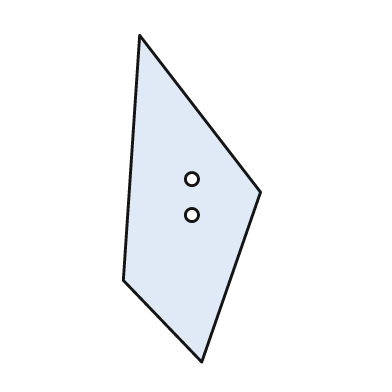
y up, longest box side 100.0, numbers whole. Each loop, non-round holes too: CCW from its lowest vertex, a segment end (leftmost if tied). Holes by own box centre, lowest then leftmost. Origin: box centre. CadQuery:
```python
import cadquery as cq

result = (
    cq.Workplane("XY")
    .moveTo(3.0, -50.0)
    .lineTo(21.0, 2.0)
    .lineTo(-16.0, 50.0)
    .lineTo(-21.0, -25.0)
    .close()
    .moveTo(0.0, -5.0)
    .circle(2.0)
    .moveTo(0.0, 6.0)
    .circle(2.0)
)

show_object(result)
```